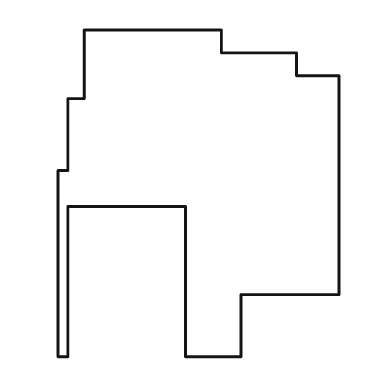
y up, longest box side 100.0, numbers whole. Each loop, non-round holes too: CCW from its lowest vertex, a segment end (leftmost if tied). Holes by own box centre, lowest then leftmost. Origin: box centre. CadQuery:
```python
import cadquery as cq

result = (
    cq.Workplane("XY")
    .moveTo(-43.0, -50.0)
    .lineTo(-40.0, -50.0)
    .lineTo(-40.0, -4.0)
    .lineTo(-4.0, -4.0)
    .lineTo(-4.0, -50.0)
    .lineTo(13.0, -50.0)
    .lineTo(13.0, -31.0)
    .lineTo(43.0, -31.0)
    .lineTo(43.0, 36.0)
    .lineTo(30.0, 36.0)
    .lineTo(30.0, 43.0)
    .lineTo(7.0, 43.0)
    .lineTo(7.0, 50.0)
    .lineTo(-35.0, 50.0)
    .lineTo(-35.0, 29.0)
    .lineTo(-40.0, 29.0)
    .lineTo(-40.0, 7.0)
    .lineTo(-43.0, 7.0)
    .close()
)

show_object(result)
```